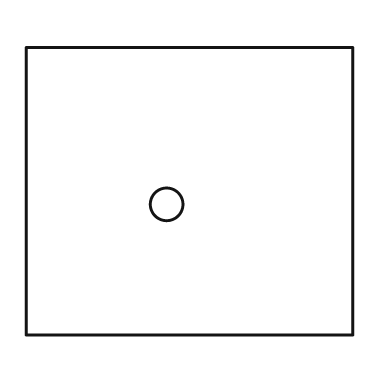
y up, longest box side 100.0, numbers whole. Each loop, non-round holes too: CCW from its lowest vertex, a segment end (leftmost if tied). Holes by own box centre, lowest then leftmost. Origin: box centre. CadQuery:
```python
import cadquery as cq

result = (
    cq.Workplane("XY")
    .moveTo(-50.0, -44.0)
    .lineTo(50.0, -44.0)
    .lineTo(50.0, 44.0)
    .lineTo(-50.0, 44.0)
    .close()
    .moveTo(-7.0, -4.0)
    .circle(5.0)
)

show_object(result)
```